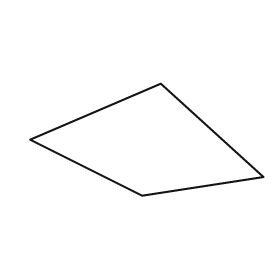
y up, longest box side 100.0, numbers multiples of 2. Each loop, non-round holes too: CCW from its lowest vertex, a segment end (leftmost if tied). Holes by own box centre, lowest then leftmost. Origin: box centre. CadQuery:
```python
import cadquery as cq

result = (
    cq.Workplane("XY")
    .moveTo(-2.0, -24.0)
    .lineTo(50.0, -16.0)
    .lineTo(6.0, 24.0)
    .lineTo(-50.0, 0.0)
    .close()
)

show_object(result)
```